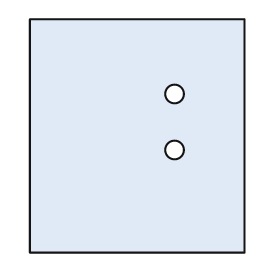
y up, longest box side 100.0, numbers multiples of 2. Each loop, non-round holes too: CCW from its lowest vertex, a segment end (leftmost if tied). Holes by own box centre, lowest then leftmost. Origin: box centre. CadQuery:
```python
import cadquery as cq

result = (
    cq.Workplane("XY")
    .moveTo(-46.0, -50.0)
    .lineTo(46.0, -50.0)
    .lineTo(46.0, 50.0)
    .lineTo(-46.0, 50.0)
    .close()
    .moveTo(16.0, -6.0)
    .circle(4.0)
    .moveTo(16.0, 18.0)
    .circle(4.0)
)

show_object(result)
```